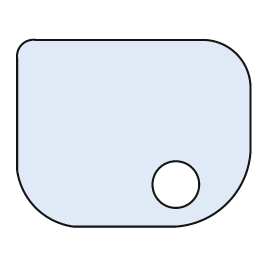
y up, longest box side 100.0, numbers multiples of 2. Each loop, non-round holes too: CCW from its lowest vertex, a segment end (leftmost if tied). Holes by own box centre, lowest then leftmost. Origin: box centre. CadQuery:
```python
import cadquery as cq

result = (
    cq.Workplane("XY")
    .moveTo(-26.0, -40.0)
    .lineTo(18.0, -40.0)
    .threePointArc((40.0, -30.0), (50.0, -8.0))
    .lineTo(50.0, 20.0)
    .threePointArc((44.0, 34.0), (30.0, 40.0))
    .lineTo(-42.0, 40.0)
    .threePointArc((-48.0, 38.0), (-50.0, 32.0))
    .lineTo(-50.0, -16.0)
    .threePointArc((-42.0, -32.0), (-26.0, -40.0))
    .close()
    .moveTo(18.0, -22.0)
    .circle(10.0)
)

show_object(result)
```